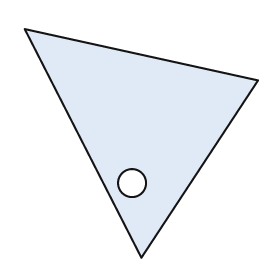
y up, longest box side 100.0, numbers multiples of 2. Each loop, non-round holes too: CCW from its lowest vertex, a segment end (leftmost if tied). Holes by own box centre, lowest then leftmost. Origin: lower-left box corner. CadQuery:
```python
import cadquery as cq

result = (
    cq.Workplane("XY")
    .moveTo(50.0, 0.0)
    .lineTo(100.0, 76.0)
    .lineTo(0.0, 98.0)
    .close()
    .moveTo(46.0, 32.0)
    .circle(6.0)
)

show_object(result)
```